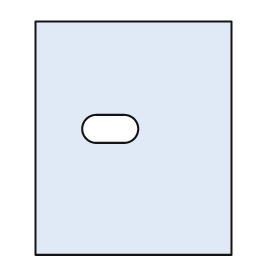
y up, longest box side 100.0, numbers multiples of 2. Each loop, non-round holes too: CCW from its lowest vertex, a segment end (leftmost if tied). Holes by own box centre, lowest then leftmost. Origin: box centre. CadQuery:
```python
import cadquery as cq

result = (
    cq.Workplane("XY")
    .moveTo(-42.0, -50.0)
    .lineTo(42.0, -50.0)
    .lineTo(42.0, 50.0)
    .lineTo(-42.0, 50.0)
    .close()
    .moveTo(-16.0, -2.0)
    .lineTo(-4.0, -2.0)
    .threePointArc((2.0, 4.0), (-4.0, 10.0))
    .lineTo(-16.0, 10.0)
    .threePointArc((-22.0, 4.0), (-16.0, -2.0))
    .close()
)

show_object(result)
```